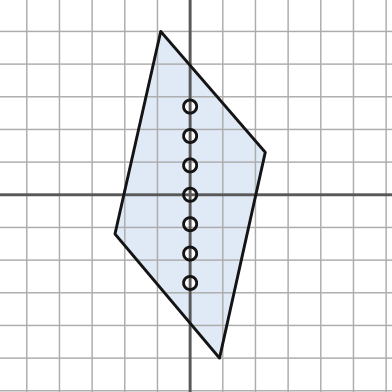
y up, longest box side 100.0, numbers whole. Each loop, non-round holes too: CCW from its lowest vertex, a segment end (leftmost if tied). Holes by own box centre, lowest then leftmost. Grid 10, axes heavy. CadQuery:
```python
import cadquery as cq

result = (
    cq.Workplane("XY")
    .moveTo(9.0, -50.0)
    .lineTo(23.0, 13.0)
    .lineTo(-9.0, 50.0)
    .lineTo(-23.0, -12.0)
    .close()
    .moveTo(0.0, -27.0)
    .circle(2.0)
    .moveTo(0.0, -18.0)
    .circle(2.0)
    .moveTo(0.0, -9.0)
    .circle(2.0)
    .moveTo(0.0, 0.0)
    .circle(2.0)
    .moveTo(0.0, 9.0)
    .circle(2.0)
    .moveTo(0.0, 18.0)
    .circle(2.0)
    .moveTo(0.0, 27.0)
    .circle(2.0)
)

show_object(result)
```